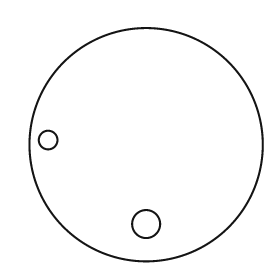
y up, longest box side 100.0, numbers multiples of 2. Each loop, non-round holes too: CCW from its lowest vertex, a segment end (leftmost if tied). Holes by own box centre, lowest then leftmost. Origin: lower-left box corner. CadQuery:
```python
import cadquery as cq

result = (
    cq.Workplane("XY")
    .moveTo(50.0, 50.0)
    .circle(50.0)
    .moveTo(50.0, 16.0)
    .circle(6.0)
    .moveTo(8.0, 52.0)
    .circle(4.0)
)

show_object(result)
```